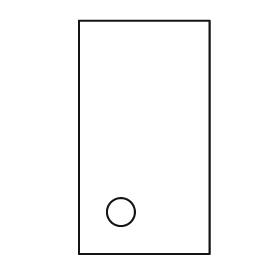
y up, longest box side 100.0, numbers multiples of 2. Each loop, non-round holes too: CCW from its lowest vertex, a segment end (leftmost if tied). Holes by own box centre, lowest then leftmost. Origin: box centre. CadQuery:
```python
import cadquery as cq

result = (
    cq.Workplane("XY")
    .moveTo(-28.0, -50.0)
    .lineTo(28.0, -50.0)
    .lineTo(28.0, 50.0)
    .lineTo(-28.0, 50.0)
    .close()
    .moveTo(-10.0, -32.0)
    .circle(6.0)
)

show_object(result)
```